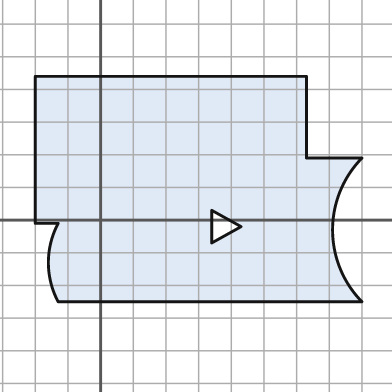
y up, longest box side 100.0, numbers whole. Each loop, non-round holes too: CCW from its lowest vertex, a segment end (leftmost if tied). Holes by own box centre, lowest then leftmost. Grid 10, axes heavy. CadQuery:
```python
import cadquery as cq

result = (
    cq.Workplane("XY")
    .moveTo(-13.0, -25.0)
    .lineTo(80.0, -25.0)
    .threePointArc((71.0, -3.0), (80.0, 19.0))
    .lineTo(63.0, 19.0)
    .lineTo(63.0, 44.0)
    .lineTo(-20.0, 44.0)
    .lineTo(-20.0, -1.0)
    .lineTo(-13.0, -1.0)
    .threePointArc((-16.0, -13.0), (-13.0, -25.0))
    .close()
    .moveTo(34.0, -7.0)
    .lineTo(43.0, -2.0)
    .lineTo(34.0, 3.0)
    .close()
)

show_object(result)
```